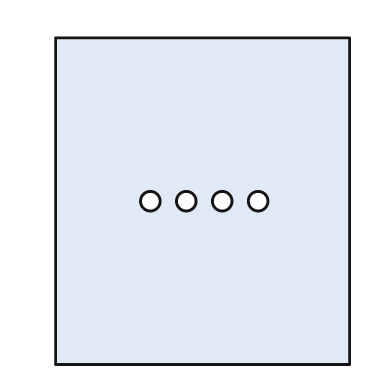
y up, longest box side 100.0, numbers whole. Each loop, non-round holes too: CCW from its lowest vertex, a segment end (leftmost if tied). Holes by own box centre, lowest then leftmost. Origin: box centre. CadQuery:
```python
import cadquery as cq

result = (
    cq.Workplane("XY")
    .moveTo(-45.0, -50.0)
    .lineTo(45.0, -50.0)
    .lineTo(45.0, 50.0)
    .lineTo(-45.0, 50.0)
    .close()
    .moveTo(-16.0, 0.0)
    .circle(3.0)
    .moveTo(-5.0, 0.0)
    .circle(3.0)
    .moveTo(6.0, 0.0)
    .circle(3.0)
    .moveTo(17.0, 0.0)
    .circle(3.0)
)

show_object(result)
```